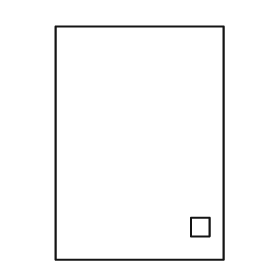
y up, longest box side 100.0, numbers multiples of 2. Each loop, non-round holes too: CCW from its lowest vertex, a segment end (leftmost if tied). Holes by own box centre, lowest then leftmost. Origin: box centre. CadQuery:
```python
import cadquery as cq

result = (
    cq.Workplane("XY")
    .moveTo(-36.0, -50.0)
    .lineTo(36.0, -50.0)
    .lineTo(36.0, 50.0)
    .lineTo(-36.0, 50.0)
    .close()
    .moveTo(22.0, -40.0)
    .lineTo(30.0, -40.0)
    .lineTo(30.0, -32.0)
    .lineTo(22.0, -32.0)
    .close()
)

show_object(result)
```